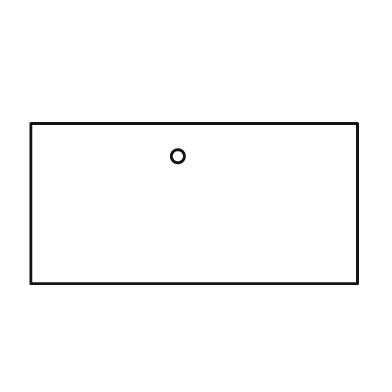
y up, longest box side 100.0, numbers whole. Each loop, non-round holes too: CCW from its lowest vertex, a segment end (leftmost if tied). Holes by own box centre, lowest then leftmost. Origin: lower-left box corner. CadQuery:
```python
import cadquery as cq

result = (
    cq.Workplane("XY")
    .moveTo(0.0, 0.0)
    .lineTo(100.0, 0.0)
    .lineTo(100.0, 49.0)
    .lineTo(0.0, 49.0)
    .close()
    .moveTo(45.0, 39.0)
    .circle(2.0)
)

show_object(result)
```